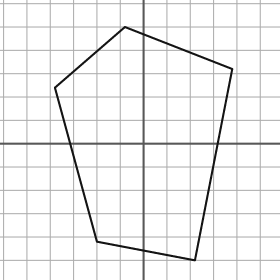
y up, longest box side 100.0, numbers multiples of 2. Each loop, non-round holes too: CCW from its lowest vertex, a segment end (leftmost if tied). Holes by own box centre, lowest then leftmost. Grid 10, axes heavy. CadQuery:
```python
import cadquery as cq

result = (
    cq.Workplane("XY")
    .moveTo(22.0, -50.0)
    .lineTo(38.0, 32.0)
    .lineTo(-8.0, 50.0)
    .lineTo(-38.0, 24.0)
    .lineTo(-20.0, -42.0)
    .close()
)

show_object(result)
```